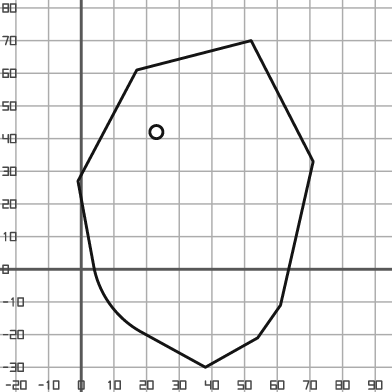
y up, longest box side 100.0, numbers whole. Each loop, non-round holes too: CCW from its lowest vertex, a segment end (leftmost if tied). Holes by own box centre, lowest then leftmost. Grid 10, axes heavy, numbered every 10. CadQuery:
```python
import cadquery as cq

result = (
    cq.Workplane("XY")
    .moveTo(38.0, -30.0)
    .lineTo(54.0, -21.0)
    .lineTo(61.0, -11.0)
    .lineTo(71.0, 33.0)
    .lineTo(52.0, 70.0)
    .lineTo(17.0, 61.0)
    .lineTo(-1.0, 27.0)
    .lineTo(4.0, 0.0)
    .threePointArc((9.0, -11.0), (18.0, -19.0))
    .close()
    .moveTo(23.0, 42.0)
    .circle(2.0)
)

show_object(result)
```